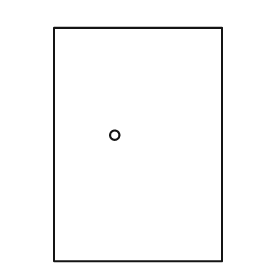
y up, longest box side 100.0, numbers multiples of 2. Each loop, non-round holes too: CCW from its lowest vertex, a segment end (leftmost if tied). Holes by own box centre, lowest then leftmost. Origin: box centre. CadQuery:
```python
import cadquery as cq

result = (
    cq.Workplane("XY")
    .moveTo(-36.0, -50.0)
    .lineTo(36.0, -50.0)
    .lineTo(36.0, 50.0)
    .lineTo(-36.0, 50.0)
    .close()
    .moveTo(-10.0, 4.0)
    .circle(2.0)
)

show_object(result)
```